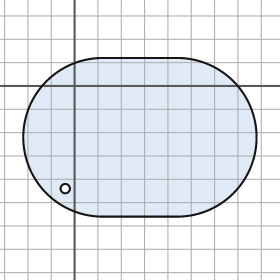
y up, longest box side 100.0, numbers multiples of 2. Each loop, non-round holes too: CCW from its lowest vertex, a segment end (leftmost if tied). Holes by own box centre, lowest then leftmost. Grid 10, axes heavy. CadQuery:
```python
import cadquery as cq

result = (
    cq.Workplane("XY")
    .moveTo(12.0, -56.0)
    .lineTo(44.0, -56.0)
    .threePointArc((78.0, -22.0), (44.0, 12.0))
    .lineTo(12.0, 12.0)
    .threePointArc((-22.0, -22.0), (12.0, -56.0))
    .close()
    .moveTo(-4.0, -44.0)
    .circle(2.0)
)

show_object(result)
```